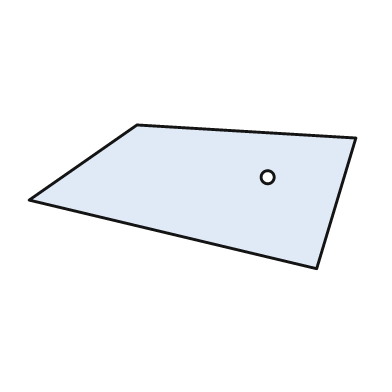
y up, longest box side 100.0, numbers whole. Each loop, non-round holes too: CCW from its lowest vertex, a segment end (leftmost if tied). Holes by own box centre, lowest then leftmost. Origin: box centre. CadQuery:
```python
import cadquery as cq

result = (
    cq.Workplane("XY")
    .moveTo(38.0, -22.0)
    .lineTo(50.0, 18.0)
    .lineTo(-17.0, 22.0)
    .lineTo(-50.0, -1.0)
    .close()
    .moveTo(23.0, 6.0)
    .circle(2.0)
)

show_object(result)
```